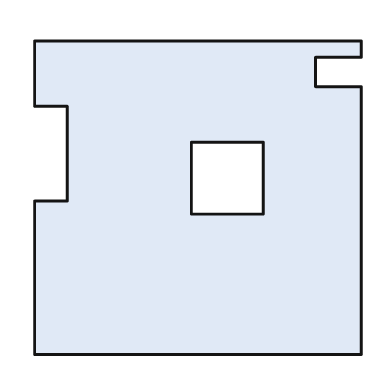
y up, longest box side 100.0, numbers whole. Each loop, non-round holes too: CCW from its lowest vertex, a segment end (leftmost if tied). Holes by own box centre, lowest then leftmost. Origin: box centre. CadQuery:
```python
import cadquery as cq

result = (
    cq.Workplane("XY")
    .moveTo(-50.0, -48.0)
    .lineTo(50.0, -48.0)
    .lineTo(50.0, 34.0)
    .lineTo(36.0, 34.0)
    .lineTo(36.0, 43.0)
    .lineTo(50.0, 43.0)
    .lineTo(50.0, 48.0)
    .lineTo(-50.0, 48.0)
    .lineTo(-50.0, 28.0)
    .lineTo(-40.0, 28.0)
    .lineTo(-40.0, -1.0)
    .lineTo(-50.0, -1.0)
    .close()
    .moveTo(-2.0, -5.0)
    .lineTo(20.0, -5.0)
    .lineTo(20.0, 17.0)
    .lineTo(-2.0, 17.0)
    .close()
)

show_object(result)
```